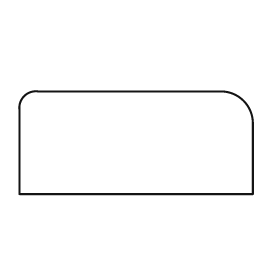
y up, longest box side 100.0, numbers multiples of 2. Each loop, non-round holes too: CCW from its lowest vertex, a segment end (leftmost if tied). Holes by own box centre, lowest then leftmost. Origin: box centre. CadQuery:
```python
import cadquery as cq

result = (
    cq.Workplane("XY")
    .moveTo(-50.0, -22.0)
    .lineTo(50.0, -22.0)
    .lineTo(50.0, 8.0)
    .threePointArc((46.0, 18.0), (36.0, 22.0))
    .lineTo(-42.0, 22.0)
    .threePointArc((-48.0, 20.0), (-50.0, 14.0))
    .close()
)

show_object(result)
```